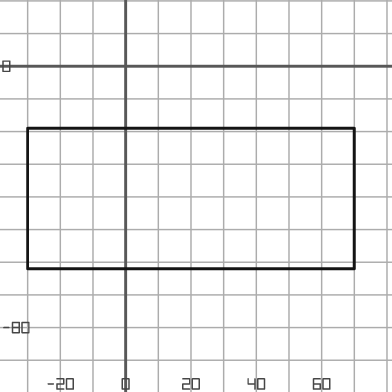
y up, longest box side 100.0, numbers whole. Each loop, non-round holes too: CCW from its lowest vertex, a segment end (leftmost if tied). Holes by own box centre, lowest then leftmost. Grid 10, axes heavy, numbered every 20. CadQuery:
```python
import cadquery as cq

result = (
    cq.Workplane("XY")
    .moveTo(-30.0, -62.0)
    .lineTo(70.0, -62.0)
    .lineTo(70.0, -19.0)
    .lineTo(-30.0, -19.0)
    .close()
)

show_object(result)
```